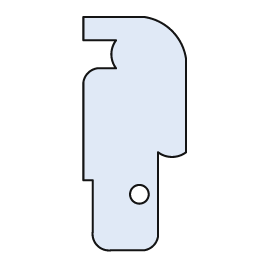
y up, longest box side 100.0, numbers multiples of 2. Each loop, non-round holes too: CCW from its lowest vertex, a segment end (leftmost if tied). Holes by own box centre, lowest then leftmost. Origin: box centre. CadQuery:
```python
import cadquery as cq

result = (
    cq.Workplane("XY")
    .moveTo(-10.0, -50.0)
    .lineTo(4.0, -50.0)
    .threePointArc((8.0, -48.0), (10.0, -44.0))
    .lineTo(10.0, -8.0)
    .threePointArc((16.0, -10.0), (22.0, -8.0))
    .lineTo(22.0, 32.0)
    .threePointArc((16.0, 44.0), (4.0, 50.0))
    .lineTo(-22.0, 50.0)
    .lineTo(-22.0, 40.0)
    .lineTo(-8.0, 40.0)
    .threePointArc((-10.0, 34.0), (-8.0, 28.0))
    .lineTo(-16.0, 28.0)
    .threePointArc((-20.0, 26.0), (-22.0, 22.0))
    .lineTo(-22.0, -20.0)
    .lineTo(-18.0, -20.0)
    .lineTo(-18.0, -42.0)
    .threePointArc((-16.0, -48.0), (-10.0, -50.0))
    .close()
    .moveTo(2.0, -26.0)
    .circle(4.0)
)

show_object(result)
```